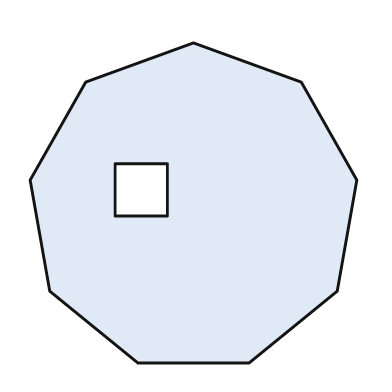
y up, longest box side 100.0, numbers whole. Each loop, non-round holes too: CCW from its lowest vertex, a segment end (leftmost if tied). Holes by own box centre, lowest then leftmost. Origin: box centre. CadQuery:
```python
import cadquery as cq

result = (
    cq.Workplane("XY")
    .moveTo(-17.0, -49.0)
    .lineTo(17.0, -49.0)
    .lineTo(44.0, -27.0)
    .lineTo(50.0, 7.0)
    .lineTo(33.0, 37.0)
    .lineTo(0.0, 49.0)
    .lineTo(-33.0, 37.0)
    .lineTo(-50.0, 7.0)
    .lineTo(-44.0, -27.0)
    .close()
    .moveTo(-24.0, -4.0)
    .lineTo(-8.0, -4.0)
    .lineTo(-8.0, 12.0)
    .lineTo(-24.0, 12.0)
    .close()
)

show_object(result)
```